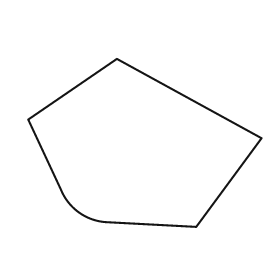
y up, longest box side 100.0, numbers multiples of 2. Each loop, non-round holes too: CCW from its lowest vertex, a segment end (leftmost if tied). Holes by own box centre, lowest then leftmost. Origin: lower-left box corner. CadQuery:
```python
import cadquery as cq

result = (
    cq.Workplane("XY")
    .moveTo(72.0, 0.0)
    .lineTo(100.0, 38.0)
    .lineTo(38.0, 72.0)
    .lineTo(0.0, 46.0)
    .lineTo(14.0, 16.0)
    .threePointArc((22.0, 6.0), (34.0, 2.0))
    .close()
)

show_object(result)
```